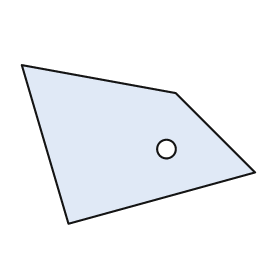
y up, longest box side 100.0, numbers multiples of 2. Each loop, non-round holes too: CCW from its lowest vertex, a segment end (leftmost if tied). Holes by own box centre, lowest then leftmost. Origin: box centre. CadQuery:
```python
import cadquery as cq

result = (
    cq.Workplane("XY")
    .moveTo(-30.0, -34.0)
    .lineTo(50.0, -12.0)
    .lineTo(16.0, 22.0)
    .lineTo(-50.0, 34.0)
    .close()
    .moveTo(12.0, -2.0)
    .circle(4.0)
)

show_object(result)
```